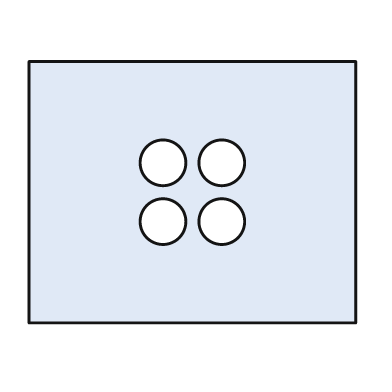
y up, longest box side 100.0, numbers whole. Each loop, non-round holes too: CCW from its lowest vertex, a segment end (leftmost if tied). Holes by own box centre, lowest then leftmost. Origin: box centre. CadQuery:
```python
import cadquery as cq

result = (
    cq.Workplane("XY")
    .moveTo(-50.0, -40.0)
    .lineTo(50.0, -40.0)
    .lineTo(50.0, 40.0)
    .lineTo(-50.0, 40.0)
    .close()
    .moveTo(-9.0, -9.0)
    .circle(7.0)
    .moveTo(9.0, -9.0)
    .circle(7.0)
    .moveTo(-9.0, 9.0)
    .circle(7.0)
    .moveTo(9.0, 9.0)
    .circle(7.0)
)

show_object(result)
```